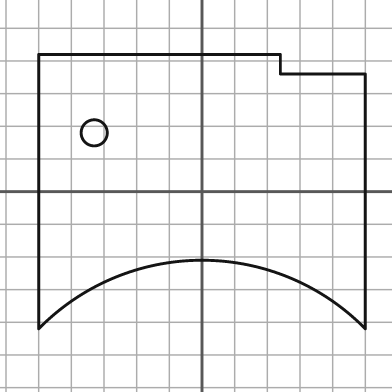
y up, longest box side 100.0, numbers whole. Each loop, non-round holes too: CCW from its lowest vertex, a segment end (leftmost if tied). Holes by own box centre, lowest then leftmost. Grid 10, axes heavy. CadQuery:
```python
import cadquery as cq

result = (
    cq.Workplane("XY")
    .moveTo(-50.0, -42.0)
    .threePointArc((0.0, -21.0), (50.0, -42.0))
    .lineTo(50.0, 36.0)
    .lineTo(24.0, 36.0)
    .lineTo(24.0, 42.0)
    .lineTo(-50.0, 42.0)
    .close()
    .moveTo(-33.0, 18.0)
    .circle(4.0)
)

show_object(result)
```